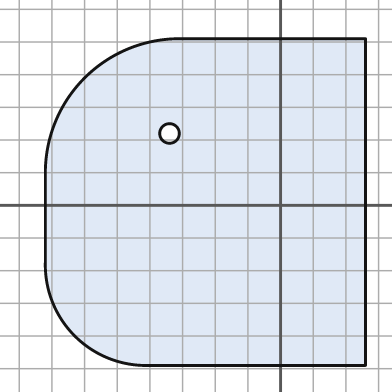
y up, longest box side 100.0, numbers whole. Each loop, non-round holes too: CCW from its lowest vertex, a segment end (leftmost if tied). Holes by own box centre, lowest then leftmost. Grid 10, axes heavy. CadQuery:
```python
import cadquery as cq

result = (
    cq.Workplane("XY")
    .moveTo(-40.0, -49.0)
    .lineTo(26.0, -49.0)
    .lineTo(26.0, 51.0)
    .lineTo(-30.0, 51.0)
    .threePointArc((-60.0, 39.0), (-72.0, 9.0))
    .lineTo(-72.0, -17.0)
    .threePointArc((-63.0, -40.0), (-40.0, -49.0))
    .close()
    .moveTo(-34.0, 22.0)
    .circle(3.0)
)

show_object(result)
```